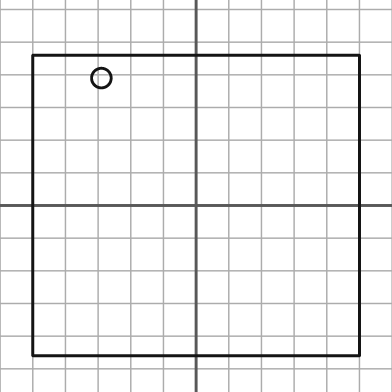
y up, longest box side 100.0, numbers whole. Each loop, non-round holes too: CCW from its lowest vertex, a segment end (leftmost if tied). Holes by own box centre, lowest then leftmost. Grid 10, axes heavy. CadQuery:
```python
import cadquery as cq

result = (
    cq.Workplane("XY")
    .moveTo(-50.0, -46.0)
    .lineTo(50.0, -46.0)
    .lineTo(50.0, 46.0)
    .lineTo(-50.0, 46.0)
    .close()
    .moveTo(-29.0, 39.0)
    .circle(3.0)
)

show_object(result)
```